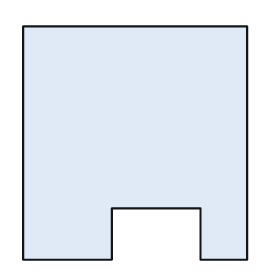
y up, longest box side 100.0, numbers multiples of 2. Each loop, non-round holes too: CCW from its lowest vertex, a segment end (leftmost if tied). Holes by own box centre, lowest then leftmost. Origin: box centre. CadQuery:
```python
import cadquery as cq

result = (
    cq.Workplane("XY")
    .moveTo(-48.0, -50.0)
    .lineTo(-10.0, -50.0)
    .lineTo(-10.0, -28.0)
    .lineTo(28.0, -28.0)
    .lineTo(28.0, -50.0)
    .lineTo(48.0, -50.0)
    .lineTo(48.0, 50.0)
    .lineTo(-48.0, 50.0)
    .close()
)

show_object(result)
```